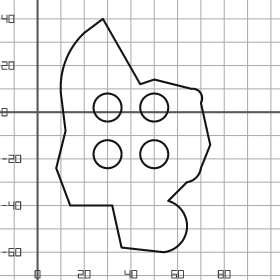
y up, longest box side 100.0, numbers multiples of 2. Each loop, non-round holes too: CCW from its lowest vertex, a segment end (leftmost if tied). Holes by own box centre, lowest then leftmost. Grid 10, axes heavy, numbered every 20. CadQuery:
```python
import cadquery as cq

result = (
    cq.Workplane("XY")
    .moveTo(54.0, -60.0)
    .threePointArc((64.0, -50.0), (56.0, -38.0))
    .lineTo(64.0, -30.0)
    .threePointArc((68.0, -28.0), (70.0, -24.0))
    .lineTo(74.0, -14.0)
    .lineTo(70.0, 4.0)
    .threePointArc((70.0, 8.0), (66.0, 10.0))
    .lineTo(50.0, 14.0)
    .lineTo(44.0, 12.0)
    .lineTo(28.0, 40.0)
    .lineTo(20.0, 34.0)
    .threePointArc((12.0, 22.0), (10.0, 8.0))
    .lineTo(12.0, -8.0)
    .lineTo(8.0, -24.0)
    .lineTo(14.0, -40.0)
    .lineTo(32.0, -40.0)
    .lineTo(36.0, -58.0)
    .close()
    .moveTo(30.0, -18.0)
    .circle(6.0)
    .moveTo(50.0, -18.0)
    .circle(6.0)
    .moveTo(30.0, 2.0)
    .circle(6.0)
    .moveTo(50.0, 2.0)
    .circle(6.0)
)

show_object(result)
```